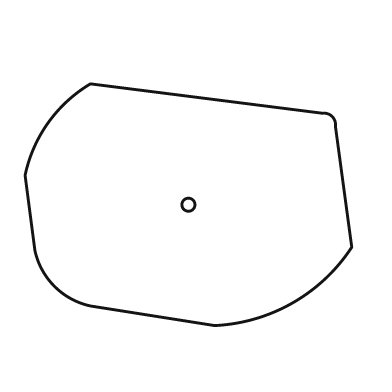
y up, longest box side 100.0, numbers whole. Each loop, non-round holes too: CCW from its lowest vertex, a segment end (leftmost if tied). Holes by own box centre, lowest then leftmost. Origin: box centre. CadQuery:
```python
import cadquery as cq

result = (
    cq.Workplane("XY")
    .moveTo(8.0, -37.0)
    .threePointArc((32.0, -30.0), (50.0, -13.0))
    .lineTo(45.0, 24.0)
    .threePointArc((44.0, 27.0), (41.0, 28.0))
    .lineTo(-30.0, 37.0)
    .threePointArc((-43.0, 25.0), (-50.0, 9.0))
    .lineTo(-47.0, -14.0)
    .threePointArc((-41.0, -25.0), (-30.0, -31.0))
    .close()
    .moveTo(0.0, 0.0)
    .circle(2.0)
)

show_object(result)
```